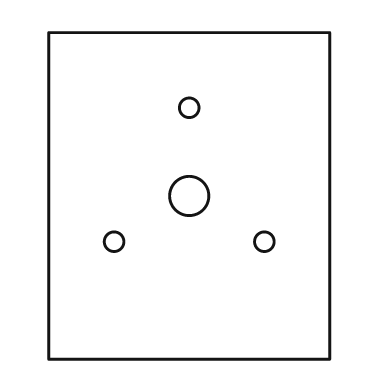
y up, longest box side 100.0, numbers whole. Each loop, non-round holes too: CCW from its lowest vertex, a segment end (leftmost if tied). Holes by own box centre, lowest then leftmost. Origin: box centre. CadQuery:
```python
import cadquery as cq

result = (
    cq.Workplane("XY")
    .moveTo(-43.0, -50.0)
    .lineTo(43.0, -50.0)
    .lineTo(43.0, 50.0)
    .lineTo(-43.0, 50.0)
    .close()
    .moveTo(-23.0, -14.0)
    .circle(3.0)
    .moveTo(23.0, -14.0)
    .circle(3.0)
    .moveTo(0.0, 0.0)
    .circle(6.0)
    .moveTo(0.0, 27.0)
    .circle(3.0)
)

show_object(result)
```